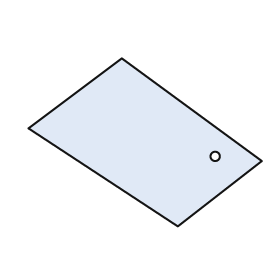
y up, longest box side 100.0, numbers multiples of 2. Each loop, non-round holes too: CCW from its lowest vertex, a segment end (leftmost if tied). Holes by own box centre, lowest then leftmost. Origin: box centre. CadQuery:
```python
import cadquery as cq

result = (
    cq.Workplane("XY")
    .moveTo(14.0, -36.0)
    .lineTo(50.0, -8.0)
    .lineTo(-10.0, 36.0)
    .lineTo(-50.0, 6.0)
    .close()
    .moveTo(30.0, -6.0)
    .circle(2.0)
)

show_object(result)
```